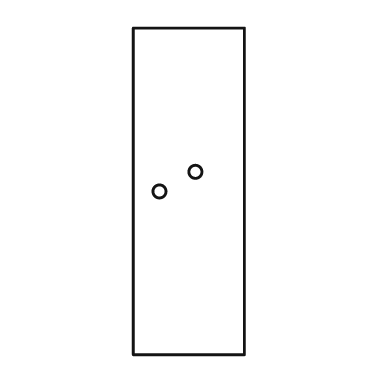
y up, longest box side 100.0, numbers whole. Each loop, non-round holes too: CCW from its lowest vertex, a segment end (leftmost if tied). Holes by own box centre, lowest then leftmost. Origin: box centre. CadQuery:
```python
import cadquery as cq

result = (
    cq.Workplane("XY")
    .moveTo(-17.0, -50.0)
    .lineTo(17.0, -50.0)
    .lineTo(17.0, 50.0)
    .lineTo(-17.0, 50.0)
    .close()
    .moveTo(-9.0, 0.0)
    .circle(2.0)
    .moveTo(2.0, 6.0)
    .circle(2.0)
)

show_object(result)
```